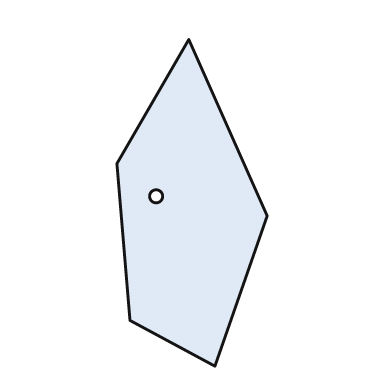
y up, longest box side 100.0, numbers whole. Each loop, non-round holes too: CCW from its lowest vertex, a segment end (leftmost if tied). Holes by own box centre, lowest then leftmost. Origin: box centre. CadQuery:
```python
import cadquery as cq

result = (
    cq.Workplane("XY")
    .moveTo(7.0, -50.0)
    .lineTo(23.0, -4.0)
    .lineTo(-1.0, 50.0)
    .lineTo(-23.0, 12.0)
    .lineTo(-19.0, -36.0)
    .close()
    .moveTo(-11.0, 2.0)
    .circle(2.0)
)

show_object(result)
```